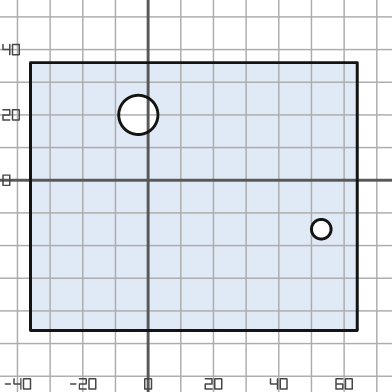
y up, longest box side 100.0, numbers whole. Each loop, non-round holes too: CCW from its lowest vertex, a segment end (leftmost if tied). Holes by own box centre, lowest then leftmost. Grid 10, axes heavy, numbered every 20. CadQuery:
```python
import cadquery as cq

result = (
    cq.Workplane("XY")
    .moveTo(-36.0, -46.0)
    .lineTo(64.0, -46.0)
    .lineTo(64.0, 36.0)
    .lineTo(-36.0, 36.0)
    .close()
    .moveTo(53.0, -15.0)
    .circle(3.0)
    .moveTo(-3.0, 20.0)
    .circle(6.0)
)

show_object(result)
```